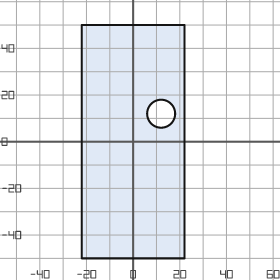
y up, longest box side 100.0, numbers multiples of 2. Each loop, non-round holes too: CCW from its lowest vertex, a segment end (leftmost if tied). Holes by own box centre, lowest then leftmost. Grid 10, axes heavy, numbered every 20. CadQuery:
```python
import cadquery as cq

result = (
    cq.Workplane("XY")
    .moveTo(-22.0, -50.0)
    .lineTo(22.0, -50.0)
    .lineTo(22.0, 50.0)
    .lineTo(-22.0, 50.0)
    .close()
    .moveTo(12.0, 12.0)
    .circle(6.0)
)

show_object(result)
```